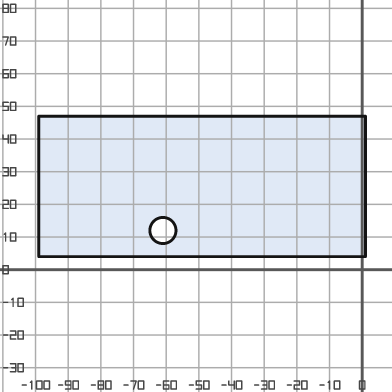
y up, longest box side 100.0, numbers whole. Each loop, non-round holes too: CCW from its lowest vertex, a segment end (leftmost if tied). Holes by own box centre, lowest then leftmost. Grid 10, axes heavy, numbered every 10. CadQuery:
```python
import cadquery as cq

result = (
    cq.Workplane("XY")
    .moveTo(-99.0, 4.0)
    .lineTo(1.0, 4.0)
    .lineTo(1.0, 47.0)
    .lineTo(-99.0, 47.0)
    .close()
    .moveTo(-61.0, 12.0)
    .circle(4.0)
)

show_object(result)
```